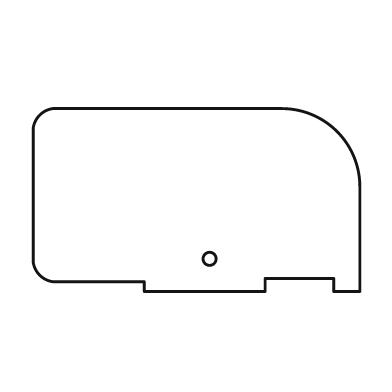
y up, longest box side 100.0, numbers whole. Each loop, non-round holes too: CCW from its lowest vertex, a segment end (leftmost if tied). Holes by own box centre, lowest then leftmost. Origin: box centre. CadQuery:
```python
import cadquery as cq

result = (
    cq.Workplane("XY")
    .moveTo(-16.0, -28.0)
    .lineTo(21.0, -28.0)
    .lineTo(21.0, -24.0)
    .lineTo(42.0, -24.0)
    .lineTo(42.0, -28.0)
    .lineTo(50.0, -28.0)
    .lineTo(50.0, 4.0)
    .threePointArc((43.0, 21.0), (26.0, 28.0))
    .lineTo(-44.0, 28.0)
    .threePointArc((-48.0, 26.0), (-50.0, 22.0))
    .lineTo(-50.0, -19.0)
    .threePointArc((-48.0, -23.0), (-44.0, -25.0))
    .lineTo(-16.0, -25.0)
    .close()
    .moveTo(4.0, -18.0)
    .circle(2.0)
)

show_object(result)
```